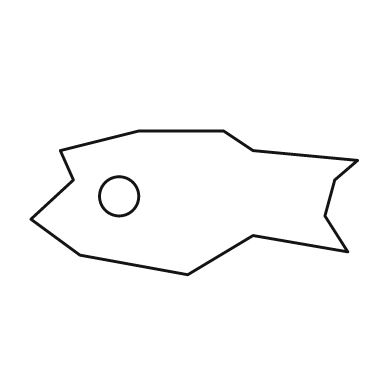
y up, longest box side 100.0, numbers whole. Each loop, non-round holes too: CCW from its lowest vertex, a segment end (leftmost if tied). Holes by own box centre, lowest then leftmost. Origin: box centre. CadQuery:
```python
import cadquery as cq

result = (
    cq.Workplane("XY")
    .moveTo(-2.0, -22.0)
    .lineTo(18.0, -10.0)
    .lineTo(47.0, -15.0)
    .lineTo(40.0, -4.0)
    .lineTo(43.0, 7.0)
    .lineTo(50.0, 13.0)
    .lineTo(18.0, 16.0)
    .lineTo(9.0, 22.0)
    .lineTo(-17.0, 22.0)
    .lineTo(-41.0, 16.0)
    .lineTo(-37.0, 7.0)
    .lineTo(-50.0, -5.0)
    .lineTo(-35.0, -16.0)
    .close()
    .moveTo(-23.0, 2.0)
    .circle(6.0)
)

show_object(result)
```